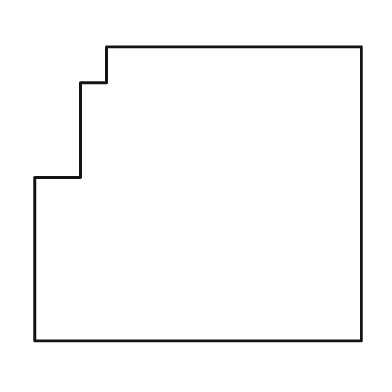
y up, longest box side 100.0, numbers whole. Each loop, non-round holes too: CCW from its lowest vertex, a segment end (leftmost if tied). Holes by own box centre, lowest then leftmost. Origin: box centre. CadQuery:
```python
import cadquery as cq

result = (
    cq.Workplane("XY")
    .moveTo(-50.0, -45.0)
    .lineTo(50.0, -45.0)
    .lineTo(50.0, 45.0)
    .lineTo(-28.0, 45.0)
    .lineTo(-28.0, 34.0)
    .lineTo(-36.0, 34.0)
    .lineTo(-36.0, 5.0)
    .lineTo(-50.0, 5.0)
    .close()
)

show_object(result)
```